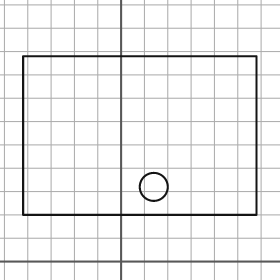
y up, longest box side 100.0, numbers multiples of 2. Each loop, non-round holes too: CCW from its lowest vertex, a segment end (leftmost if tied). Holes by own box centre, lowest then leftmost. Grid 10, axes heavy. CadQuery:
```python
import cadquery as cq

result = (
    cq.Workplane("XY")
    .moveTo(-42.0, 20.0)
    .lineTo(58.0, 20.0)
    .lineTo(58.0, 88.0)
    .lineTo(-42.0, 88.0)
    .close()
    .moveTo(14.0, 32.0)
    .circle(6.0)
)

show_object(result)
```